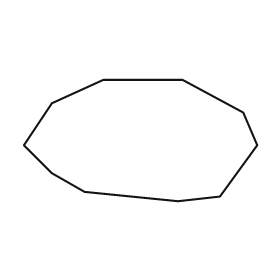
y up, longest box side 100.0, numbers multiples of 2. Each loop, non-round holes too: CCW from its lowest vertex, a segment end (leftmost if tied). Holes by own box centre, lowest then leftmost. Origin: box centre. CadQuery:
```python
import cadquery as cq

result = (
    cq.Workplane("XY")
    .moveTo(16.0, -26.0)
    .lineTo(34.0, -24.0)
    .lineTo(50.0, -2.0)
    .lineTo(44.0, 12.0)
    .lineTo(18.0, 26.0)
    .lineTo(-16.0, 26.0)
    .lineTo(-38.0, 16.0)
    .lineTo(-50.0, -2.0)
    .lineTo(-38.0, -14.0)
    .lineTo(-24.0, -22.0)
    .close()
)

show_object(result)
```